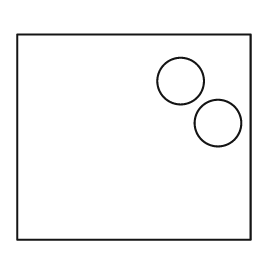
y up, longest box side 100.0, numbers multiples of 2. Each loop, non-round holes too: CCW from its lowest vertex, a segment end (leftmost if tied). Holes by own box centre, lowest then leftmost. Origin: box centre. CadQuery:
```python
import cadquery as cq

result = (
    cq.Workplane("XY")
    .moveTo(-50.0, -44.0)
    .lineTo(50.0, -44.0)
    .lineTo(50.0, 44.0)
    .lineTo(-50.0, 44.0)
    .close()
    .moveTo(36.0, 6.0)
    .circle(10.0)
    .moveTo(20.0, 24.0)
    .circle(10.0)
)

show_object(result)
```